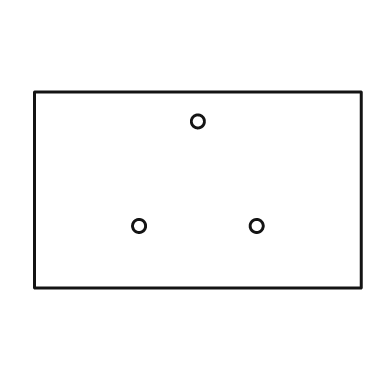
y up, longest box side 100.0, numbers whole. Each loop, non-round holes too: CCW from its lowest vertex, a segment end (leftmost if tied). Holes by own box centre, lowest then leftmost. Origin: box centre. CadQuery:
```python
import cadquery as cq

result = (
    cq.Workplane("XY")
    .moveTo(-50.0, -30.0)
    .lineTo(50.0, -30.0)
    .lineTo(50.0, 30.0)
    .lineTo(-50.0, 30.0)
    .close()
    .moveTo(-18.0, -11.0)
    .circle(2.0)
    .moveTo(18.0, -11.0)
    .circle(2.0)
    .moveTo(0.0, 21.0)
    .circle(2.0)
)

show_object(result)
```